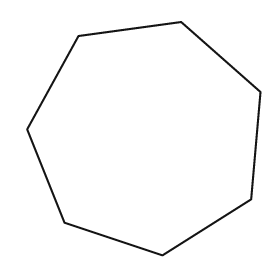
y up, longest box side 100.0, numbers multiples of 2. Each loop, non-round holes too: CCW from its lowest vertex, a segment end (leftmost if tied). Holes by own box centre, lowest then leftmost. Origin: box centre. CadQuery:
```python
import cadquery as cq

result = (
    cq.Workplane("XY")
    .moveTo(8.0, -50.0)
    .lineTo(46.0, -26.0)
    .lineTo(50.0, 20.0)
    .lineTo(16.0, 50.0)
    .lineTo(-28.0, 44.0)
    .lineTo(-50.0, 4.0)
    .lineTo(-34.0, -36.0)
    .close()
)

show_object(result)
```